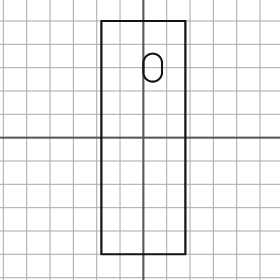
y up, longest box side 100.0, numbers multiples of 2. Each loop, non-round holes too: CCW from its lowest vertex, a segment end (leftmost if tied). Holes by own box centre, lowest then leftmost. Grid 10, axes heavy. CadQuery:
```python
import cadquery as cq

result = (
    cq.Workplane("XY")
    .moveTo(-18.0, -50.0)
    .lineTo(18.0, -50.0)
    .lineTo(18.0, 50.0)
    .lineTo(-18.0, 50.0)
    .close()
    .moveTo(0.0, 28.0)
    .threePointArc((4.0, 24.0), (8.0, 28.0))
    .lineTo(8.0, 32.0)
    .threePointArc((4.0, 36.0), (0.0, 32.0))
    .close()
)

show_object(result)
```